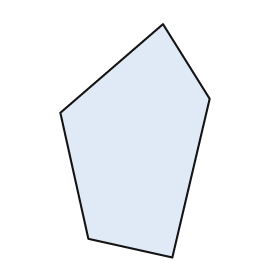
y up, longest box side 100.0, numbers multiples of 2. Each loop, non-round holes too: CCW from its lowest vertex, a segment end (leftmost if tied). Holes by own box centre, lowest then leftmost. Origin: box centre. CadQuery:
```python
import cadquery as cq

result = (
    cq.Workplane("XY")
    .moveTo(16.0, -50.0)
    .lineTo(32.0, 18.0)
    .lineTo(12.0, 50.0)
    .lineTo(-32.0, 12.0)
    .lineTo(-20.0, -42.0)
    .close()
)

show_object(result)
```